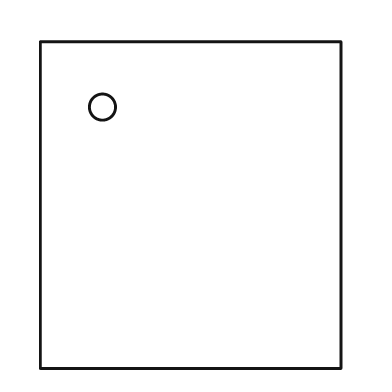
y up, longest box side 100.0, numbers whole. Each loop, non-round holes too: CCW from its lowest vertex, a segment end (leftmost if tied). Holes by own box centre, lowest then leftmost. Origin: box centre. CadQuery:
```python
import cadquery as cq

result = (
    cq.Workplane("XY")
    .moveTo(-46.0, -50.0)
    .lineTo(46.0, -50.0)
    .lineTo(46.0, 50.0)
    .lineTo(-46.0, 50.0)
    .close()
    .moveTo(-27.0, 30.0)
    .circle(4.0)
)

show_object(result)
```